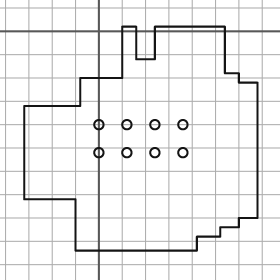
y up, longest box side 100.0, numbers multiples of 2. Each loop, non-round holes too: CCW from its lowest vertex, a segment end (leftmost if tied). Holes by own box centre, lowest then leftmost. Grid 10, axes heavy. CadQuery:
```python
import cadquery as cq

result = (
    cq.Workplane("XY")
    .moveTo(-10.0, -94.0)
    .lineTo(42.0, -94.0)
    .lineTo(42.0, -88.0)
    .lineTo(52.0, -88.0)
    .lineTo(52.0, -84.0)
    .lineTo(60.0, -84.0)
    .lineTo(60.0, -80.0)
    .lineTo(68.0, -80.0)
    .lineTo(68.0, -22.0)
    .lineTo(60.0, -22.0)
    .lineTo(60.0, -18.0)
    .lineTo(54.0, -18.0)
    .lineTo(54.0, 2.0)
    .lineTo(24.0, 2.0)
    .lineTo(24.0, -12.0)
    .lineTo(16.0, -12.0)
    .lineTo(16.0, 2.0)
    .lineTo(10.0, 2.0)
    .lineTo(10.0, -20.0)
    .lineTo(-8.0, -20.0)
    .lineTo(-8.0, -32.0)
    .lineTo(-32.0, -32.0)
    .lineTo(-32.0, -72.0)
    .lineTo(-10.0, -72.0)
    .close()
    .moveTo(0.0, -52.0)
    .circle(2.0)
    .moveTo(12.0, -52.0)
    .circle(2.0)
    .moveTo(24.0, -52.0)
    .circle(2.0)
    .moveTo(36.0, -52.0)
    .circle(2.0)
    .moveTo(0.0, -40.0)
    .circle(2.0)
    .moveTo(12.0, -40.0)
    .circle(2.0)
    .moveTo(24.0, -40.0)
    .circle(2.0)
    .moveTo(36.0, -40.0)
    .circle(2.0)
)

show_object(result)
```